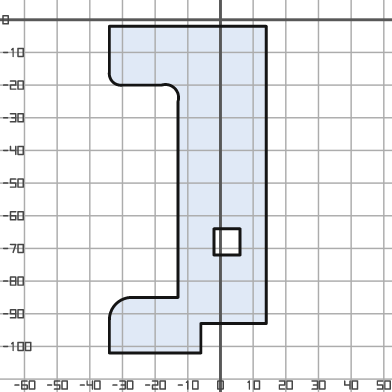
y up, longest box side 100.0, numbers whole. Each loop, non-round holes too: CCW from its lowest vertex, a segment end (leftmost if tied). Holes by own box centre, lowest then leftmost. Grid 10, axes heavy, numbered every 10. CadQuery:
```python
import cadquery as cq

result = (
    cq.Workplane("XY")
    .moveTo(-34.0, -102.0)
    .lineTo(-6.0, -102.0)
    .lineTo(-6.0, -93.0)
    .lineTo(14.0, -93.0)
    .lineTo(14.0, -2.0)
    .lineTo(-34.0, -2.0)
    .lineTo(-34.0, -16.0)
    .threePointArc((-33.0, -19.0), (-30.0, -20.0))
    .lineTo(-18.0, -20.0)
    .threePointArc((-14.0, -21.0), (-13.0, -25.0))
    .lineTo(-13.0, -85.0)
    .lineTo(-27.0, -85.0)
    .threePointArc((-32.0, -87.0), (-34.0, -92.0))
    .close()
    .moveTo(-2.0, -72.0)
    .lineTo(6.0, -72.0)
    .lineTo(6.0, -64.0)
    .lineTo(-2.0, -64.0)
    .close()
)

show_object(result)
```